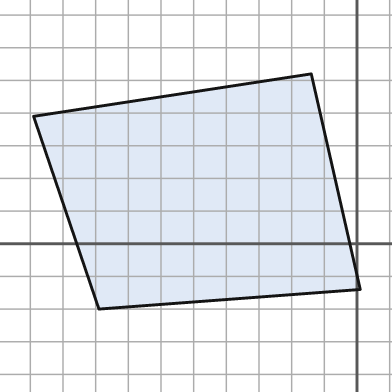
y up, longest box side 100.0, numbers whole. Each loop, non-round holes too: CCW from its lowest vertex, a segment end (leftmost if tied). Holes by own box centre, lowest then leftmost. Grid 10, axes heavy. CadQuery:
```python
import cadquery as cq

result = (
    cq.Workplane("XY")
    .moveTo(-79.0, -20.0)
    .lineTo(1.0, -14.0)
    .lineTo(-14.0, 52.0)
    .lineTo(-99.0, 39.0)
    .close()
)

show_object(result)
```